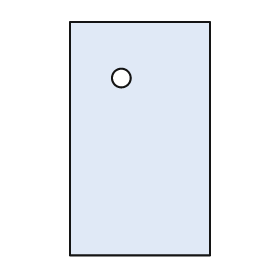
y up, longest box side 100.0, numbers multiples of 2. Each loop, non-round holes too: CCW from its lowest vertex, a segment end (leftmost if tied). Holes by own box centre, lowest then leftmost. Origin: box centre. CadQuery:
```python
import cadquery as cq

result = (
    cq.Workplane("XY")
    .moveTo(-30.0, -50.0)
    .lineTo(30.0, -50.0)
    .lineTo(30.0, 50.0)
    .lineTo(-30.0, 50.0)
    .close()
    .moveTo(-8.0, 26.0)
    .circle(4.0)
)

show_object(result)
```